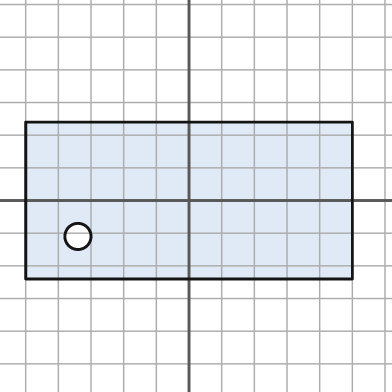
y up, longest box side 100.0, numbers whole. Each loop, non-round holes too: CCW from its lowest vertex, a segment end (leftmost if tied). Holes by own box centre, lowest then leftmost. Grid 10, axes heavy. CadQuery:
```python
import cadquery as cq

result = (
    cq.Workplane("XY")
    .moveTo(-50.0, -24.0)
    .lineTo(50.0, -24.0)
    .lineTo(50.0, 24.0)
    .lineTo(-50.0, 24.0)
    .close()
    .moveTo(-34.0, -11.0)
    .circle(4.0)
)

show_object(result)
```